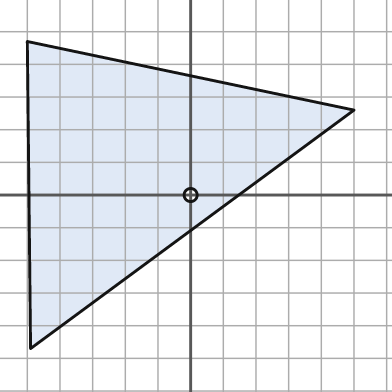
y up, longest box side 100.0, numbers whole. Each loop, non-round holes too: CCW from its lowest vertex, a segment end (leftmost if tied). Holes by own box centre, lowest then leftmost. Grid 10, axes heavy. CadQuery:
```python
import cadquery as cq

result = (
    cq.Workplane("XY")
    .moveTo(-49.0, -47.0)
    .lineTo(50.0, 26.0)
    .lineTo(-50.0, 47.0)
    .close()
    .moveTo(0.0, 0.0)
    .circle(2.0)
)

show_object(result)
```